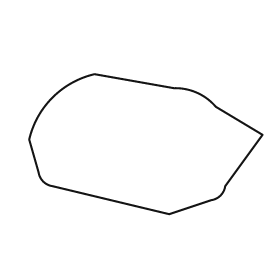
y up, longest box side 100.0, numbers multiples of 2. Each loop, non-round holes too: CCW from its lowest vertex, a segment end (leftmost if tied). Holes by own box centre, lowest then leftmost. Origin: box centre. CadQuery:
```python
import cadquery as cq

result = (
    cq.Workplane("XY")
    .moveTo(10.0, -30.0)
    .lineTo(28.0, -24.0)
    .threePointArc((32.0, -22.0), (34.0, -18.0))
    .lineTo(50.0, 4.0)
    .lineTo(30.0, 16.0)
    .threePointArc((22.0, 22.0), (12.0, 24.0))
    .lineTo(-22.0, 30.0)
    .threePointArc((-40.0, 20.0), (-50.0, 2.0))
    .lineTo(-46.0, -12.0)
    .threePointArc((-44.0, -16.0), (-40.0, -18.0))
    .close()
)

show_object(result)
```